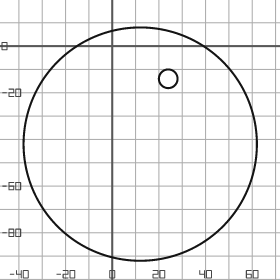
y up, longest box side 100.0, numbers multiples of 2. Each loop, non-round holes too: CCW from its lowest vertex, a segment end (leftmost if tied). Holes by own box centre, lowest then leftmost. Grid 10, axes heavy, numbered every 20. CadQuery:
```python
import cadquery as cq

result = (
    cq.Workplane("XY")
    .moveTo(12.0, -42.0)
    .circle(50.0)
    .moveTo(24.0, -14.0)
    .circle(4.0)
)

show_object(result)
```